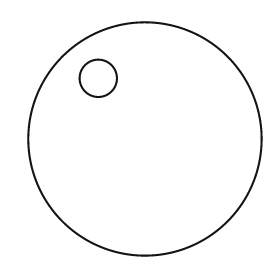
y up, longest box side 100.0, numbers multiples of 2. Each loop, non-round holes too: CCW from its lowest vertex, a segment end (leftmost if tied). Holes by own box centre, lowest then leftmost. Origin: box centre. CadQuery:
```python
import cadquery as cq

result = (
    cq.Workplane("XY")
    .moveTo(0.0, 0.0)
    .circle(50.0)
    .moveTo(-20.0, 26.0)
    .circle(8.0)
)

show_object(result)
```